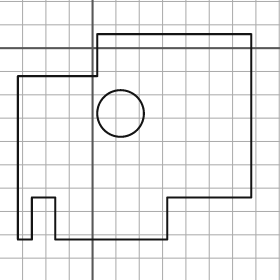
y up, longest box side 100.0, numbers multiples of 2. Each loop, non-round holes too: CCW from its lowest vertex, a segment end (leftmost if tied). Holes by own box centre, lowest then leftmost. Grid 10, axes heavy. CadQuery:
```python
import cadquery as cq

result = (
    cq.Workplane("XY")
    .moveTo(-32.0, -82.0)
    .lineTo(-26.0, -82.0)
    .lineTo(-26.0, -64.0)
    .lineTo(-16.0, -64.0)
    .lineTo(-16.0, -82.0)
    .lineTo(32.0, -82.0)
    .lineTo(32.0, -64.0)
    .lineTo(68.0, -64.0)
    .lineTo(68.0, 6.0)
    .lineTo(2.0, 6.0)
    .lineTo(2.0, -12.0)
    .lineTo(-32.0, -12.0)
    .close()
    .moveTo(12.0, -28.0)
    .circle(10.0)
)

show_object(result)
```